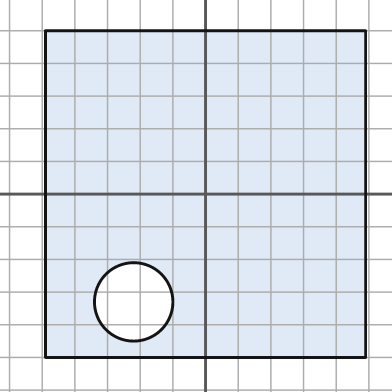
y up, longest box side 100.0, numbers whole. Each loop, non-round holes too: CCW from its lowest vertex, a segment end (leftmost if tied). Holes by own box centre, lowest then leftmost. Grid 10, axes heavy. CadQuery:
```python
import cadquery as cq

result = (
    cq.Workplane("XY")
    .moveTo(-49.0, -50.0)
    .lineTo(49.0, -50.0)
    .lineTo(49.0, 50.0)
    .lineTo(-49.0, 50.0)
    .close()
    .moveTo(-22.0, -33.0)
    .circle(12.0)
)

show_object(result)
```